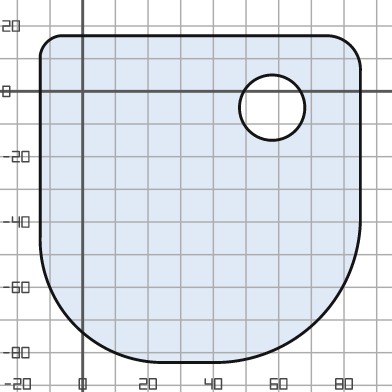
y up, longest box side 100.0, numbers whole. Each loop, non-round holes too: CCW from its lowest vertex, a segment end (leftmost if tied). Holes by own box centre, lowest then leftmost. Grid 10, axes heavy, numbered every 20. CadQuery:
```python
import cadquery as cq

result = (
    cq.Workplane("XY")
    .moveTo(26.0, -83.0)
    .lineTo(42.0, -83.0)
    .threePointArc((72.0, -70.0), (85.0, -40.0))
    .lineTo(85.0, 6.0)
    .threePointArc((82.0, 14.0), (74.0, 17.0))
    .lineTo(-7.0, 17.0)
    .threePointArc((-11.0, 15.0), (-13.0, 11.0))
    .lineTo(-13.0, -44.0)
    .threePointArc((-2.0, -72.0), (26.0, -83.0))
    .close()
    .moveTo(58.0, -5.0)
    .circle(10.0)
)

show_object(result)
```